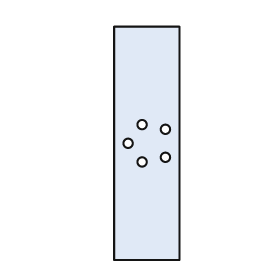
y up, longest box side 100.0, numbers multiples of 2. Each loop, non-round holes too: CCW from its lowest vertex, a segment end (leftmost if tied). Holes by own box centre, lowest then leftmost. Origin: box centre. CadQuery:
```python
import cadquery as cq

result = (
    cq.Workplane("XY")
    .moveTo(-14.0, -50.0)
    .lineTo(14.0, -50.0)
    .lineTo(14.0, 50.0)
    .lineTo(-14.0, 50.0)
    .close()
    .moveTo(-2.0, -8.0)
    .circle(2.0)
    .moveTo(8.0, -6.0)
    .circle(2.0)
    .moveTo(-8.0, 0.0)
    .circle(2.0)
    .moveTo(8.0, 6.0)
    .circle(2.0)
    .moveTo(-2.0, 8.0)
    .circle(2.0)
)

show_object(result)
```